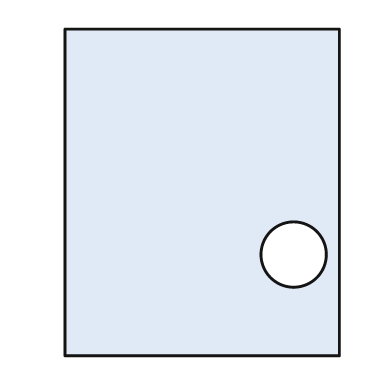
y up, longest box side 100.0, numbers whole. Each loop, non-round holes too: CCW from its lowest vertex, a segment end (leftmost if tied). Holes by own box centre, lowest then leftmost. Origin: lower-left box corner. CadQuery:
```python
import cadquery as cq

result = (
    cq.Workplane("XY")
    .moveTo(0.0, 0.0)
    .lineTo(84.0, 0.0)
    .lineTo(84.0, 100.0)
    .lineTo(0.0, 100.0)
    .close()
    .moveTo(70.0, 31.0)
    .circle(10.0)
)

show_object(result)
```